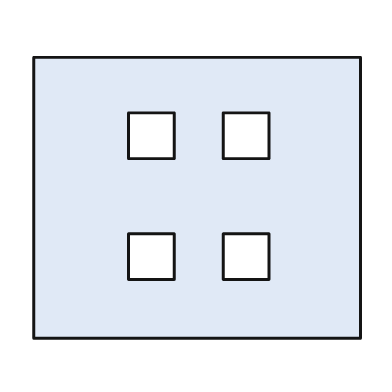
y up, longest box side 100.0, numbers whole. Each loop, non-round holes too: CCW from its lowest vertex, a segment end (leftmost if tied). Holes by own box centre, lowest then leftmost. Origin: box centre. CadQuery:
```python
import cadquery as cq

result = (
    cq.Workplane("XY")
    .moveTo(-50.0, -43.0)
    .lineTo(50.0, -43.0)
    .lineTo(50.0, 43.0)
    .lineTo(-50.0, 43.0)
    .close()
    .moveTo(-21.0, -25.0)
    .lineTo(-7.0, -25.0)
    .lineTo(-7.0, -11.0)
    .lineTo(-21.0, -11.0)
    .close()
    .moveTo(8.0, -25.0)
    .lineTo(22.0, -25.0)
    .lineTo(22.0, -11.0)
    .lineTo(8.0, -11.0)
    .close()
    .moveTo(-21.0, 12.0)
    .lineTo(-7.0, 12.0)
    .lineTo(-7.0, 26.0)
    .lineTo(-21.0, 26.0)
    .close()
    .moveTo(8.0, 12.0)
    .lineTo(22.0, 12.0)
    .lineTo(22.0, 26.0)
    .lineTo(8.0, 26.0)
    .close()
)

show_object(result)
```